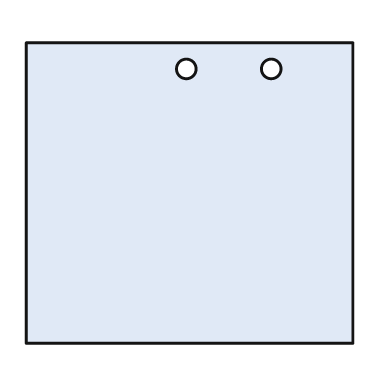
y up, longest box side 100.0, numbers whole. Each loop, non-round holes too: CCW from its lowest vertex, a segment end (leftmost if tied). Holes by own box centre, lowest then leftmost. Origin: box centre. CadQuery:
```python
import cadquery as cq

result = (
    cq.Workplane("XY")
    .moveTo(-50.0, -46.0)
    .lineTo(50.0, -46.0)
    .lineTo(50.0, 46.0)
    .lineTo(-50.0, 46.0)
    .close()
    .moveTo(-1.0, 38.0)
    .circle(3.0)
    .moveTo(25.0, 38.0)
    .circle(3.0)
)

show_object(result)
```